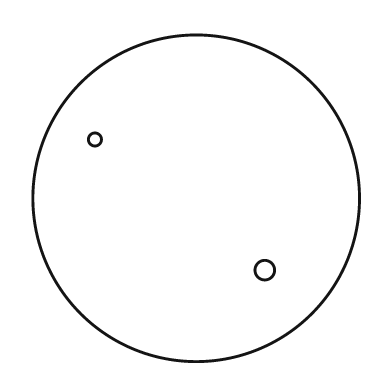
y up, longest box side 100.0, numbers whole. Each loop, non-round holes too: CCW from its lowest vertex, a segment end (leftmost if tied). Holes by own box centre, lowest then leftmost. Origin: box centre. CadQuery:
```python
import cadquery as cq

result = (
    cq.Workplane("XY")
    .moveTo(0.0, 0.0)
    .circle(50.0)
    .moveTo(21.0, -22.0)
    .circle(3.0)
    .moveTo(-31.0, 18.0)
    .circle(2.0)
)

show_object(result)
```